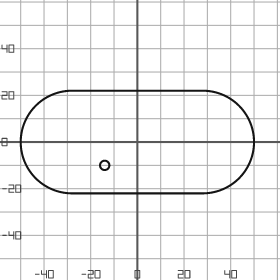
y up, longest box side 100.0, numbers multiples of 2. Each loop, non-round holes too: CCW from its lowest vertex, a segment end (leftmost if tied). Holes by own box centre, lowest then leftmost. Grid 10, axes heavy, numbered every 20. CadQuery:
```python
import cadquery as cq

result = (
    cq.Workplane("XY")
    .moveTo(-28.0, -22.0)
    .lineTo(28.0, -22.0)
    .threePointArc((50.0, 0.0), (28.0, 22.0))
    .lineTo(-28.0, 22.0)
    .threePointArc((-50.0, 0.0), (-28.0, -22.0))
    .close()
    .moveTo(-14.0, -10.0)
    .circle(2.0)
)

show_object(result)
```